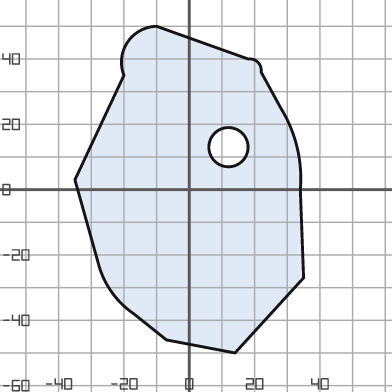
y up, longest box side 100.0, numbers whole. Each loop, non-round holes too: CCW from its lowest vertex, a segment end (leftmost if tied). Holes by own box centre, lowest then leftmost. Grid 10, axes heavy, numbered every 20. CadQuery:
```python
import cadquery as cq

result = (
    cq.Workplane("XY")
    .moveTo(14.0, -50.0)
    .lineTo(35.0, -27.0)
    .lineTo(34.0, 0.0)
    .threePointArc((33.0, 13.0), (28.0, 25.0))
    .lineTo(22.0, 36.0)
    .threePointArc((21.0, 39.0), (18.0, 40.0))
    .lineTo(-10.0, 50.0)
    .threePointArc((-19.0, 45.0), (-20.0, 35.0))
    .lineTo(-35.0, 3.0)
    .lineTo(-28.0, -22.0)
    .threePointArc((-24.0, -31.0), (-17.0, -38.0))
    .lineTo(-7.0, -46.0)
    .close()
    .moveTo(12.0, 13.0)
    .circle(6.0)
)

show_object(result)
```